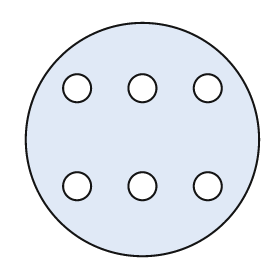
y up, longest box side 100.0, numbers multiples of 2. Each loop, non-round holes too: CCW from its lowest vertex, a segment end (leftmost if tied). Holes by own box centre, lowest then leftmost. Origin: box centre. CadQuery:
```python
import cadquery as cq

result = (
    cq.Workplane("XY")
    .moveTo(0.0, 0.0)
    .circle(50.0)
    .moveTo(-28.0, -20.0)
    .circle(6.0)
    .moveTo(0.0, -20.0)
    .circle(6.0)
    .moveTo(28.0, -20.0)
    .circle(6.0)
    .moveTo(-28.0, 22.0)
    .circle(6.0)
    .moveTo(0.0, 22.0)
    .circle(6.0)
    .moveTo(28.0, 22.0)
    .circle(6.0)
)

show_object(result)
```